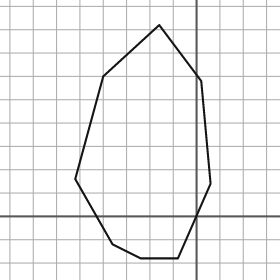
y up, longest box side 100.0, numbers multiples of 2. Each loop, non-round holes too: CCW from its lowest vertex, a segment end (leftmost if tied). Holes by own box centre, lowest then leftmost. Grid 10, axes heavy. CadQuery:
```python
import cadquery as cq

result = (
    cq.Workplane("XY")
    .moveTo(-24.0, -18.0)
    .lineTo(-8.0, -18.0)
    .lineTo(6.0, 14.0)
    .lineTo(2.0, 58.0)
    .lineTo(-16.0, 82.0)
    .lineTo(-40.0, 60.0)
    .lineTo(-52.0, 16.0)
    .lineTo(-36.0, -12.0)
    .close()
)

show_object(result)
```